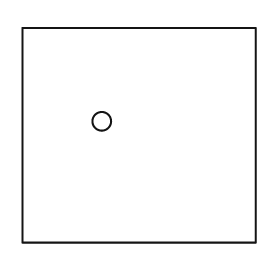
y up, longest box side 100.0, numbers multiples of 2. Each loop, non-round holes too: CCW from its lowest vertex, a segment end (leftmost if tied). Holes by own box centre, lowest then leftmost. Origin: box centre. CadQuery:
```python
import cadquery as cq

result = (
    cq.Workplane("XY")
    .moveTo(-50.0, -46.0)
    .lineTo(50.0, -46.0)
    .lineTo(50.0, 46.0)
    .lineTo(-50.0, 46.0)
    .close()
    .moveTo(-16.0, 6.0)
    .circle(4.0)
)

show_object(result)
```